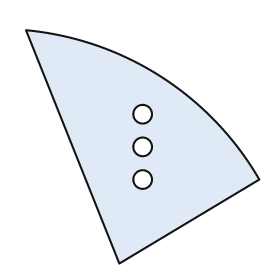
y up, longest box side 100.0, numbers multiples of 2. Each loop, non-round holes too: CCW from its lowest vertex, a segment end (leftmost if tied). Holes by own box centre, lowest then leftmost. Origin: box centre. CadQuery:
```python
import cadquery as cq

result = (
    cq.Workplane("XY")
    .moveTo(-10.0, -50.0)
    .lineTo(50.0, -14.0)
    .threePointArc((8.0, 30.0), (-50.0, 50.0))
    .close()
    .moveTo(0.0, -14.0)
    .circle(4.0)
    .moveTo(0.0, 0.0)
    .circle(4.0)
    .moveTo(0.0, 14.0)
    .circle(4.0)
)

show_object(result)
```